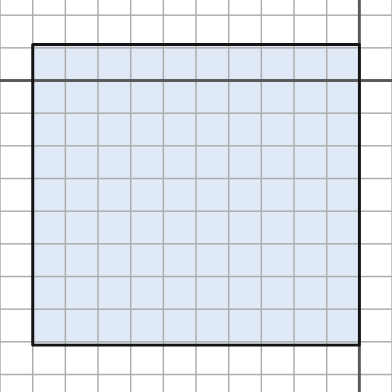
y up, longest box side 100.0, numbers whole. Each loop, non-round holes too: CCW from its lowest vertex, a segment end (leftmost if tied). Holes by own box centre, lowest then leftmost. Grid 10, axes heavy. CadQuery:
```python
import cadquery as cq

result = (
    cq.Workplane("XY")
    .moveTo(-100.0, -81.0)
    .lineTo(0.0, -81.0)
    .lineTo(0.0, 11.0)
    .lineTo(-100.0, 11.0)
    .close()
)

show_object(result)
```